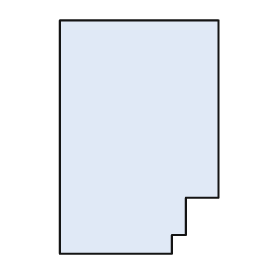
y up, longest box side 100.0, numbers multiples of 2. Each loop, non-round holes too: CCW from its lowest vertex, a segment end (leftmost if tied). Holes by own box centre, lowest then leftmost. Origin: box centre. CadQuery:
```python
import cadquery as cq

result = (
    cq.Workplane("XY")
    .moveTo(-34.0, -50.0)
    .lineTo(14.0, -50.0)
    .lineTo(14.0, -42.0)
    .lineTo(20.0, -42.0)
    .lineTo(20.0, -26.0)
    .lineTo(34.0, -26.0)
    .lineTo(34.0, 50.0)
    .lineTo(-34.0, 50.0)
    .close()
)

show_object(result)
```